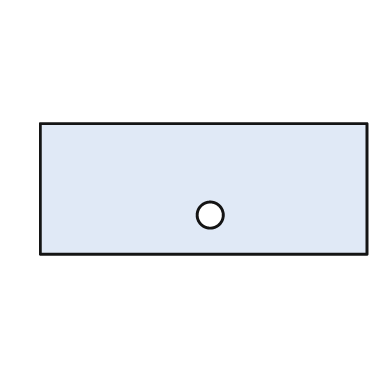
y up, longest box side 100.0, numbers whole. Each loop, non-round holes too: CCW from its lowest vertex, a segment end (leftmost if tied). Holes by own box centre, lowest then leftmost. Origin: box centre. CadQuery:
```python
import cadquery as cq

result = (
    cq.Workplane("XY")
    .moveTo(-50.0, -20.0)
    .lineTo(50.0, -20.0)
    .lineTo(50.0, 20.0)
    .lineTo(-50.0, 20.0)
    .close()
    .moveTo(2.0, -8.0)
    .circle(4.0)
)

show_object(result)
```